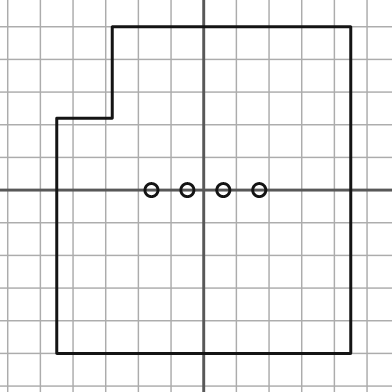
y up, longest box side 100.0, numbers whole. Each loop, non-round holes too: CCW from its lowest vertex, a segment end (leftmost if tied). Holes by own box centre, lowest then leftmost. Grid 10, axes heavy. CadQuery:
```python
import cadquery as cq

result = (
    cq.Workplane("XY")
    .moveTo(-45.0, -50.0)
    .lineTo(45.0, -50.0)
    .lineTo(45.0, 50.0)
    .lineTo(-28.0, 50.0)
    .lineTo(-28.0, 22.0)
    .lineTo(-45.0, 22.0)
    .close()
    .moveTo(-16.0, 0.0)
    .circle(2.0)
    .moveTo(-5.0, 0.0)
    .circle(2.0)
    .moveTo(6.0, 0.0)
    .circle(2.0)
    .moveTo(17.0, 0.0)
    .circle(2.0)
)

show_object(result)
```